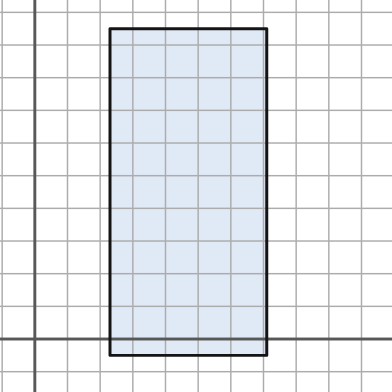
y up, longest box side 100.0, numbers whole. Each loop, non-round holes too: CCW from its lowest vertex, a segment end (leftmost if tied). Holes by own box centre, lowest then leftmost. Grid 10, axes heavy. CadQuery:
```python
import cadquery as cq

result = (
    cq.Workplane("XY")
    .moveTo(23.0, -5.0)
    .lineTo(71.0, -5.0)
    .lineTo(71.0, 95.0)
    .lineTo(23.0, 95.0)
    .close()
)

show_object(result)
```